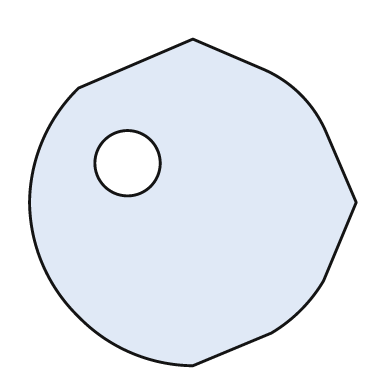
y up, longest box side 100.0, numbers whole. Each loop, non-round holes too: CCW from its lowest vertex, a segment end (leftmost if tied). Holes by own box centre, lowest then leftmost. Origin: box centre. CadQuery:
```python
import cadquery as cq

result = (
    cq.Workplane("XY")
    .moveTo(0.0, -50.0)
    .lineTo(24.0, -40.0)
    .threePointArc((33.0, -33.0), (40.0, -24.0))
    .lineTo(50.0, 0.0)
    .lineTo(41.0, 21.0)
    .threePointArc((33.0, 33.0), (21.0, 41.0))
    .lineTo(0.0, 50.0)
    .lineTo(-35.0, 35.0)
    .threePointArc((-46.0, 19.0), (-50.0, 0.0))
    .threePointArc((-46.0, -19.0), (-35.0, -35.0))
    .threePointArc((-19.0, -46.0), (0.0, -50.0))
    .close()
    .moveTo(-20.0, 12.0)
    .circle(10.0)
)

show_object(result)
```